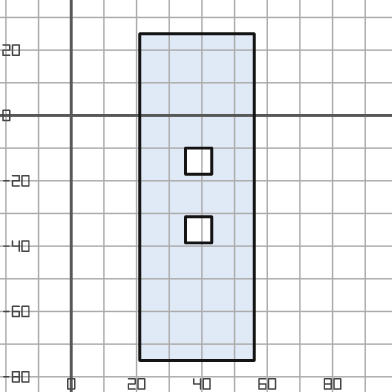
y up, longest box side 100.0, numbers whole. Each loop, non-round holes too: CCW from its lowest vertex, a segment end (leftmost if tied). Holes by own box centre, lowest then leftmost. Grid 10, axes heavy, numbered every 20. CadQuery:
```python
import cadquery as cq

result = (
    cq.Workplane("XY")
    .moveTo(21.0, -75.0)
    .lineTo(56.0, -75.0)
    .lineTo(56.0, 25.0)
    .lineTo(21.0, 25.0)
    .close()
    .moveTo(35.0, -39.0)
    .lineTo(43.0, -39.0)
    .lineTo(43.0, -31.0)
    .lineTo(35.0, -31.0)
    .close()
    .moveTo(35.0, -18.0)
    .lineTo(43.0, -18.0)
    .lineTo(43.0, -10.0)
    .lineTo(35.0, -10.0)
    .close()
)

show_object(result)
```